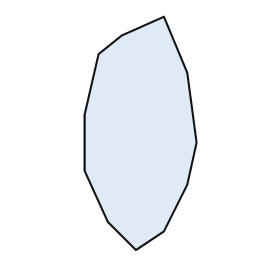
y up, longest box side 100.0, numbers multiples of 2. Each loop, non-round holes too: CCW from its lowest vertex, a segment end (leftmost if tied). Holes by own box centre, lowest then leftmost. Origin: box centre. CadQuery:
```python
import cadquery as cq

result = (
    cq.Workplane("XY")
    .moveTo(-2.0, -50.0)
    .lineTo(10.0, -42.0)
    .lineTo(20.0, -22.0)
    .lineTo(24.0, -4.0)
    .lineTo(20.0, 26.0)
    .lineTo(10.0, 50.0)
    .lineTo(-8.0, 42.0)
    .lineTo(-18.0, 34.0)
    .lineTo(-24.0, 8.0)
    .lineTo(-24.0, -16.0)
    .lineTo(-14.0, -38.0)
    .close()
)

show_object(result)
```